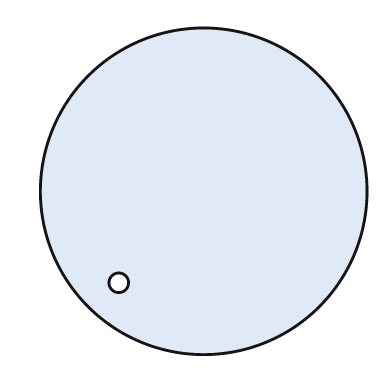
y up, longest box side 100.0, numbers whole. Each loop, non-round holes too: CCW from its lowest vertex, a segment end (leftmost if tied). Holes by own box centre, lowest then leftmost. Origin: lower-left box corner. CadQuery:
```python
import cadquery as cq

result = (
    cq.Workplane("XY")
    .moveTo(50.0, 50.0)
    .circle(50.0)
    .moveTo(24.0, 22.0)
    .circle(3.0)
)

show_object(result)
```